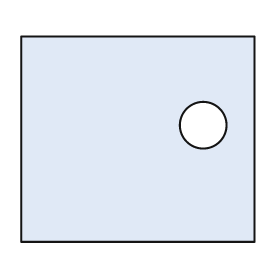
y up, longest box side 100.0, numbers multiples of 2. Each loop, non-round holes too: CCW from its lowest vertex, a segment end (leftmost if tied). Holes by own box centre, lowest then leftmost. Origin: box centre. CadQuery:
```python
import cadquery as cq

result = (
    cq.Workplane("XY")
    .moveTo(-50.0, -44.0)
    .lineTo(50.0, -44.0)
    .lineTo(50.0, 44.0)
    .lineTo(-50.0, 44.0)
    .close()
    .moveTo(28.0, 6.0)
    .circle(10.0)
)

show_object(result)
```